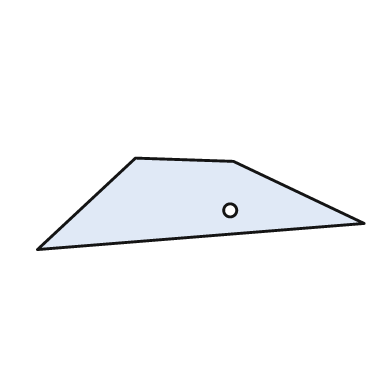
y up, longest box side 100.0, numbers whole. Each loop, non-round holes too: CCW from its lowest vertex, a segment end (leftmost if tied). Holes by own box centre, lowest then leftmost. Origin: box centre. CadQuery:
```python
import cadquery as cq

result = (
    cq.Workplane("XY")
    .moveTo(-50.0, -14.0)
    .lineTo(50.0, -6.0)
    .lineTo(10.0, 13.0)
    .lineTo(-20.0, 14.0)
    .close()
    .moveTo(9.0, -2.0)
    .circle(2.0)
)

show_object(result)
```